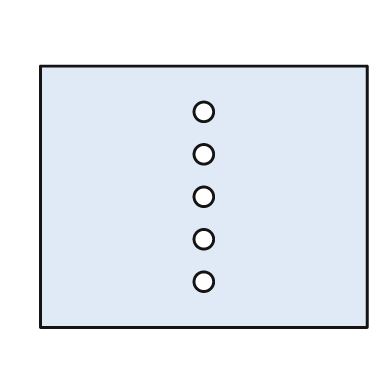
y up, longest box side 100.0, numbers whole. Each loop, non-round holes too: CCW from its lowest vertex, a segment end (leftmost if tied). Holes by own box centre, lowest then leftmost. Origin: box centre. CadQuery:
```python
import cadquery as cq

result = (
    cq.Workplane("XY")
    .moveTo(-50.0, -40.0)
    .lineTo(50.0, -40.0)
    .lineTo(50.0, 40.0)
    .lineTo(-50.0, 40.0)
    .close()
    .moveTo(0.0, -26.0)
    .circle(3.0)
    .moveTo(0.0, -13.0)
    .circle(3.0)
    .moveTo(0.0, 0.0)
    .circle(3.0)
    .moveTo(0.0, 13.0)
    .circle(3.0)
    .moveTo(0.0, 26.0)
    .circle(3.0)
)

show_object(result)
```